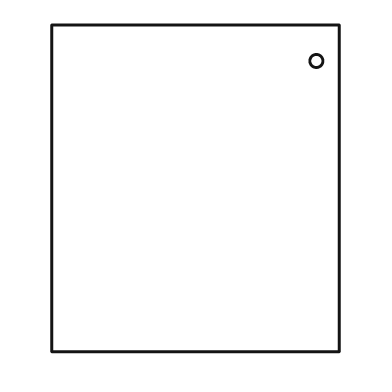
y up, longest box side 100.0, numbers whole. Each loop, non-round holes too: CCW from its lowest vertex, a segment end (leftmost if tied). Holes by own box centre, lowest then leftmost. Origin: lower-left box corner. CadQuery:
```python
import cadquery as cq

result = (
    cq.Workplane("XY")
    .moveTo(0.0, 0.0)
    .lineTo(88.0, 0.0)
    .lineTo(88.0, 100.0)
    .lineTo(0.0, 100.0)
    .close()
    .moveTo(81.0, 89.0)
    .circle(2.0)
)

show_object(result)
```